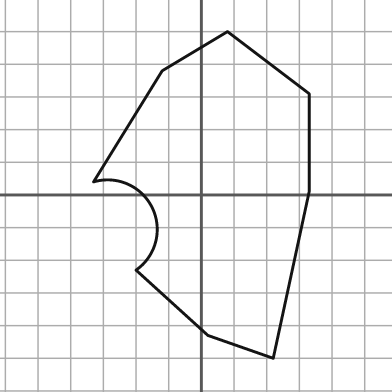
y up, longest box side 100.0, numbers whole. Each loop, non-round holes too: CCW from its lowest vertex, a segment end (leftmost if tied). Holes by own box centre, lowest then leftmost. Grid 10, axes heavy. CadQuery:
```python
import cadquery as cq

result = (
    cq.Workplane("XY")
    .moveTo(22.0, -50.0)
    .lineTo(33.0, 1.0)
    .lineTo(33.0, 31.0)
    .lineTo(8.0, 50.0)
    .lineTo(-12.0, 38.0)
    .lineTo(-33.0, 4.0)
    .threePointArc((-15.0, -4.0), (-20.0, -23.0))
    .lineTo(2.0, -43.0)
    .close()
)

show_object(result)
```